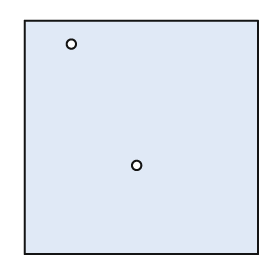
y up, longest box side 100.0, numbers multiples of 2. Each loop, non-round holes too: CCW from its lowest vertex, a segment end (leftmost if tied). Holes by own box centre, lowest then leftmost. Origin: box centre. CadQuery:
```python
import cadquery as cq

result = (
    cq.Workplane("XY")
    .moveTo(-50.0, -50.0)
    .lineTo(50.0, -50.0)
    .lineTo(50.0, 50.0)
    .lineTo(-50.0, 50.0)
    .close()
    .moveTo(-2.0, -12.0)
    .circle(2.0)
    .moveTo(-30.0, 40.0)
    .circle(2.0)
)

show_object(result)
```